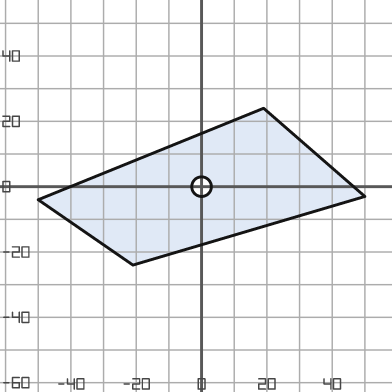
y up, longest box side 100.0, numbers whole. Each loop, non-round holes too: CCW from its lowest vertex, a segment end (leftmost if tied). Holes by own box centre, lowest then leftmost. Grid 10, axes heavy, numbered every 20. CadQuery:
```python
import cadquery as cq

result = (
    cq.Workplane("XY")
    .moveTo(-21.0, -24.0)
    .lineTo(50.0, -3.0)
    .lineTo(19.0, 24.0)
    .lineTo(-50.0, -4.0)
    .close()
    .moveTo(0.0, 0.0)
    .circle(3.0)
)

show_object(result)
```